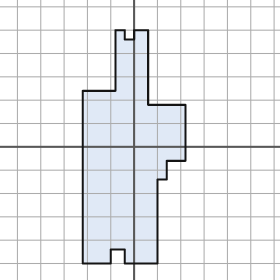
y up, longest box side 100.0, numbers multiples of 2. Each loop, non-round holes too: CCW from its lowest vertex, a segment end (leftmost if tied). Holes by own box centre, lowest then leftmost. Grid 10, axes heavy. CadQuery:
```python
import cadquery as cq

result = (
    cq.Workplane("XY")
    .moveTo(-22.0, -50.0)
    .lineTo(-10.0, -50.0)
    .lineTo(-10.0, -44.0)
    .lineTo(-4.0, -44.0)
    .lineTo(-4.0, -50.0)
    .lineTo(10.0, -50.0)
    .lineTo(10.0, -14.0)
    .lineTo(14.0, -14.0)
    .lineTo(14.0, -6.0)
    .lineTo(22.0, -6.0)
    .lineTo(22.0, 18.0)
    .lineTo(6.0, 18.0)
    .lineTo(6.0, 50.0)
    .lineTo(0.0, 50.0)
    .lineTo(0.0, 46.0)
    .lineTo(-4.0, 46.0)
    .lineTo(-4.0, 50.0)
    .lineTo(-8.0, 50.0)
    .lineTo(-8.0, 24.0)
    .lineTo(-22.0, 24.0)
    .close()
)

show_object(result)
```